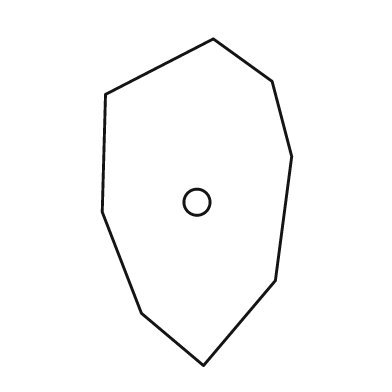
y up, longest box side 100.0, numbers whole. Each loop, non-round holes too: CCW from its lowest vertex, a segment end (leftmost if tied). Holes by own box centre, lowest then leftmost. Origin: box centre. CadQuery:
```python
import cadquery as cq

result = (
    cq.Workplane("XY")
    .moveTo(2.0, -50.0)
    .lineTo(24.0, -24.0)
    .lineTo(29.0, 14.0)
    .lineTo(23.0, 37.0)
    .lineTo(5.0, 50.0)
    .lineTo(-28.0, 33.0)
    .lineTo(-29.0, -3.0)
    .lineTo(-17.0, -34.0)
    .close()
    .moveTo(0.0, 0.0)
    .circle(4.0)
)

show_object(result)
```